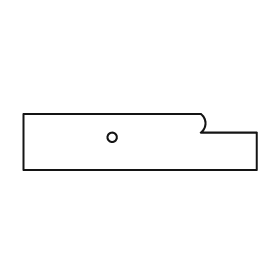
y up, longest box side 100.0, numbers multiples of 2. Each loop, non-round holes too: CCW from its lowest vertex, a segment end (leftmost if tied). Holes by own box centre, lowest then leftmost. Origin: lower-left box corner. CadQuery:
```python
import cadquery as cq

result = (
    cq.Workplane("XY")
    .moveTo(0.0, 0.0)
    .lineTo(100.0, 0.0)
    .lineTo(100.0, 16.0)
    .lineTo(76.0, 16.0)
    .threePointArc((78.0, 20.0), (76.0, 24.0))
    .lineTo(0.0, 24.0)
    .close()
    .moveTo(38.0, 14.0)
    .circle(2.0)
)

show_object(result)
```